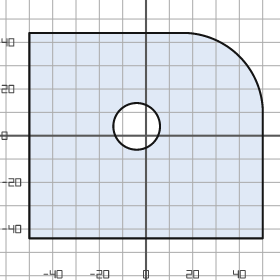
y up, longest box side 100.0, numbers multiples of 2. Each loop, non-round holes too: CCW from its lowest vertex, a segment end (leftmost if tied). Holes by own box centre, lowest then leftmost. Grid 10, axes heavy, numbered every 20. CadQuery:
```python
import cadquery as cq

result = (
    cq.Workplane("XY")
    .moveTo(-50.0, -44.0)
    .lineTo(50.0, -44.0)
    .lineTo(50.0, 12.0)
    .threePointArc((40.0, 34.0), (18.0, 44.0))
    .lineTo(-50.0, 44.0)
    .close()
    .moveTo(-4.0, 4.0)
    .circle(10.0)
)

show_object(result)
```